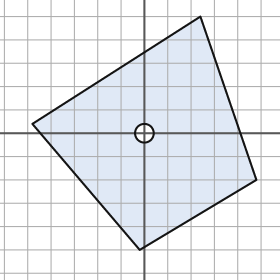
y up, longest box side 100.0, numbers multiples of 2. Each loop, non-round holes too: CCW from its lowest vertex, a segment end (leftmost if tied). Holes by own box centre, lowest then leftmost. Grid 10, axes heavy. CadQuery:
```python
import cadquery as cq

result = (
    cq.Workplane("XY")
    .moveTo(-2.0, -50.0)
    .lineTo(48.0, -20.0)
    .lineTo(24.0, 50.0)
    .lineTo(-48.0, 4.0)
    .close()
    .moveTo(0.0, 0.0)
    .circle(4.0)
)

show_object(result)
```